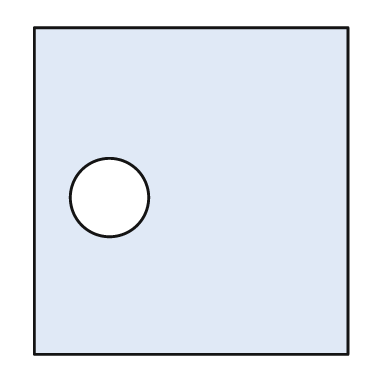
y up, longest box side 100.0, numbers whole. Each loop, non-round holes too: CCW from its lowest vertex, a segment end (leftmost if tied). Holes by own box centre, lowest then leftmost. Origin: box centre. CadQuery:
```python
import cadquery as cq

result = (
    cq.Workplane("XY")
    .moveTo(-48.0, -50.0)
    .lineTo(48.0, -50.0)
    .lineTo(48.0, 50.0)
    .lineTo(-48.0, 50.0)
    .close()
    .moveTo(-25.0, -2.0)
    .circle(12.0)
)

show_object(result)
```